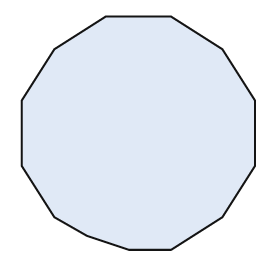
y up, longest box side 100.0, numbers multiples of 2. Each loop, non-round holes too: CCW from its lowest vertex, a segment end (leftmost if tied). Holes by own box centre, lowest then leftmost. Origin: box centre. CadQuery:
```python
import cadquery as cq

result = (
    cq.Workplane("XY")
    .moveTo(-4.0, -50.0)
    .lineTo(14.0, -50.0)
    .lineTo(36.0, -36.0)
    .lineTo(50.0, -14.0)
    .lineTo(50.0, 14.0)
    .lineTo(36.0, 36.0)
    .lineTo(14.0, 50.0)
    .lineTo(-14.0, 50.0)
    .lineTo(-36.0, 36.0)
    .lineTo(-50.0, 14.0)
    .lineTo(-50.0, -14.0)
    .lineTo(-36.0, -36.0)
    .lineTo(-22.0, -44.0)
    .close()
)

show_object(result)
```